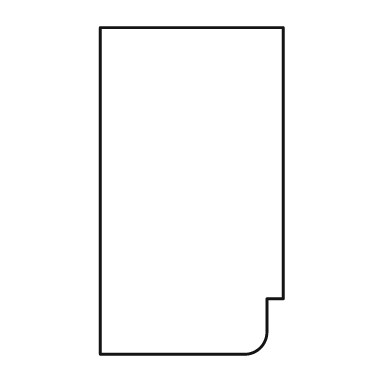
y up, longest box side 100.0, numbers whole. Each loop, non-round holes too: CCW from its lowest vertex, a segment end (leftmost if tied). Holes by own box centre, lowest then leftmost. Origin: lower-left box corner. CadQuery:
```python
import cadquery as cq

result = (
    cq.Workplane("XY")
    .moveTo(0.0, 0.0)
    .lineTo(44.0, 0.0)
    .threePointArc((49.0, 2.0), (51.0, 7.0))
    .lineTo(51.0, 17.0)
    .lineTo(56.0, 17.0)
    .lineTo(56.0, 100.0)
    .lineTo(0.0, 100.0)
    .close()
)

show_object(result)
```